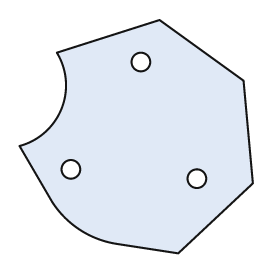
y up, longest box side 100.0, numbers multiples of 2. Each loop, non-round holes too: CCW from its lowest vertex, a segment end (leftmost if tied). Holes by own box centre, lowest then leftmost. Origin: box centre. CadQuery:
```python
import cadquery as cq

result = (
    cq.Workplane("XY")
    .moveTo(18.0, -50.0)
    .lineTo(50.0, -20.0)
    .lineTo(46.0, 24.0)
    .lineTo(10.0, 50.0)
    .lineTo(-34.0, 36.0)
    .threePointArc((-32.0, 12.0), (-50.0, -4.0))
    .lineTo(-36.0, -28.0)
    .threePointArc((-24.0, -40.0), (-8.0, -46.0))
    .close()
    .moveTo(26.0, -18.0)
    .circle(4.0)
    .moveTo(-28.0, -14.0)
    .circle(4.0)
    .moveTo(2.0, 32.0)
    .circle(4.0)
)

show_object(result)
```